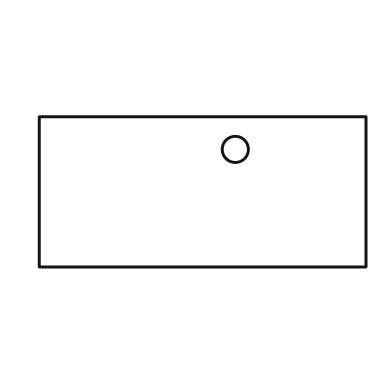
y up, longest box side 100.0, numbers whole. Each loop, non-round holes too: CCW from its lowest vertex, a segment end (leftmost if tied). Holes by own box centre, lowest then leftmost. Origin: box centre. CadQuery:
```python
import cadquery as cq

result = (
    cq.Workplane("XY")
    .moveTo(-50.0, -23.0)
    .lineTo(50.0, -23.0)
    .lineTo(50.0, 23.0)
    .lineTo(-50.0, 23.0)
    .close()
    .moveTo(10.0, 13.0)
    .circle(4.0)
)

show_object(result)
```